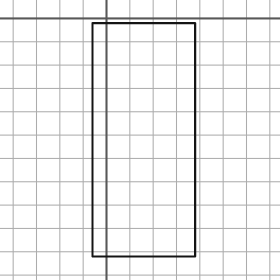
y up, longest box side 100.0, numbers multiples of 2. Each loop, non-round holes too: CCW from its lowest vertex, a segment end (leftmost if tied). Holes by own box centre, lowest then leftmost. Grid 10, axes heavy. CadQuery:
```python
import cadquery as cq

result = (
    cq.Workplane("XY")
    .moveTo(-6.0, -102.0)
    .lineTo(38.0, -102.0)
    .lineTo(38.0, -2.0)
    .lineTo(-6.0, -2.0)
    .close()
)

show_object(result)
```